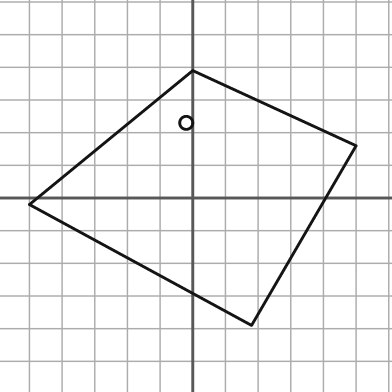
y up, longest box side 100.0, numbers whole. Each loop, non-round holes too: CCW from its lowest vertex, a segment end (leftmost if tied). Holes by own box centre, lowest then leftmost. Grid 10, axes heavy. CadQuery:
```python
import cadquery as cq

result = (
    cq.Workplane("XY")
    .moveTo(18.0, -39.0)
    .lineTo(50.0, 16.0)
    .lineTo(0.0, 39.0)
    .lineTo(-50.0, -2.0)
    .close()
    .moveTo(-2.0, 23.0)
    .circle(2.0)
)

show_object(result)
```